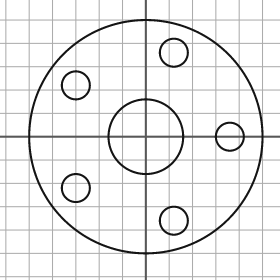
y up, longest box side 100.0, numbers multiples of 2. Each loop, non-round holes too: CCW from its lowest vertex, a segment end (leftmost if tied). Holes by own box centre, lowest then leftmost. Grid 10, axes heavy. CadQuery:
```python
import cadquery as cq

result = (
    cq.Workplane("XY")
    .moveTo(0.0, 0.0)
    .circle(50.0)
    .moveTo(12.0, -36.0)
    .circle(6.0)
    .moveTo(-30.0, -22.0)
    .circle(6.0)
    .moveTo(0.0, 0.0)
    .circle(16.0)
    .moveTo(36.0, 0.0)
    .circle(6.0)
    .moveTo(-30.0, 22.0)
    .circle(6.0)
    .moveTo(12.0, 36.0)
    .circle(6.0)
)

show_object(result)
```